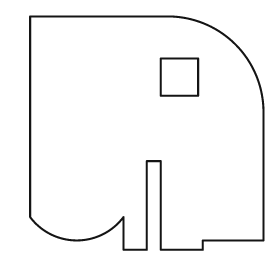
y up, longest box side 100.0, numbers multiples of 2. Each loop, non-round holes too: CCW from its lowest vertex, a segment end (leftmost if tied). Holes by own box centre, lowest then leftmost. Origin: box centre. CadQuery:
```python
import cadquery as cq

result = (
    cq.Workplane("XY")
    .moveTo(-10.0, -50.0)
    .lineTo(0.0, -50.0)
    .lineTo(0.0, -12.0)
    .lineTo(6.0, -12.0)
    .lineTo(6.0, -50.0)
    .lineTo(24.0, -50.0)
    .lineTo(24.0, -46.0)
    .lineTo(50.0, -46.0)
    .lineTo(50.0, 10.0)
    .threePointArc((38.0, 38.0), (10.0, 50.0))
    .lineTo(-50.0, 50.0)
    .lineTo(-50.0, -36.0)
    .threePointArc((-30.0, -46.0), (-10.0, -36.0))
    .close()
    .moveTo(6.0, 16.0)
    .lineTo(22.0, 16.0)
    .lineTo(22.0, 32.0)
    .lineTo(6.0, 32.0)
    .close()
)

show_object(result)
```